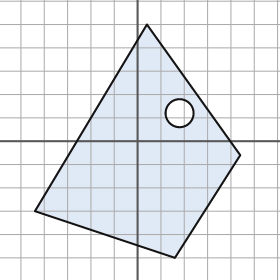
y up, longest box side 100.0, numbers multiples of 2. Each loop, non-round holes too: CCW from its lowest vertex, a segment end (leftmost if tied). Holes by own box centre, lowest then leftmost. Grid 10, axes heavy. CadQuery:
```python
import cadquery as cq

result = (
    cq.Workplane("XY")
    .moveTo(16.0, -50.0)
    .lineTo(44.0, -6.0)
    .lineTo(4.0, 50.0)
    .lineTo(-44.0, -30.0)
    .close()
    .moveTo(18.0, 12.0)
    .circle(6.0)
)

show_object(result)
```